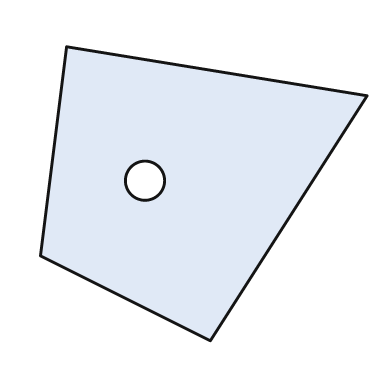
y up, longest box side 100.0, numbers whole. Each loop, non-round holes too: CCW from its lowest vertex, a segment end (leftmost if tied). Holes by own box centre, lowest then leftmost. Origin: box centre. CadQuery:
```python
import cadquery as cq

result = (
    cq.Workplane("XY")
    .moveTo(2.0, -45.0)
    .lineTo(50.0, 30.0)
    .lineTo(-42.0, 45.0)
    .lineTo(-50.0, -19.0)
    .close()
    .moveTo(-18.0, 4.0)
    .circle(6.0)
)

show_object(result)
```